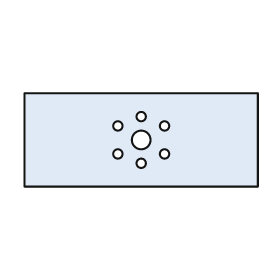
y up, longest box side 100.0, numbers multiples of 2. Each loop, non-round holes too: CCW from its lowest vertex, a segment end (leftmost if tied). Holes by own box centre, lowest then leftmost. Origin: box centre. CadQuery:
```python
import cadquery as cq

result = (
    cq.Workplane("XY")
    .moveTo(-50.0, -20.0)
    .lineTo(50.0, -20.0)
    .lineTo(50.0, 20.0)
    .lineTo(-50.0, 20.0)
    .close()
    .moveTo(0.0, -10.0)
    .circle(2.0)
    .moveTo(-10.0, -6.0)
    .circle(2.0)
    .moveTo(10.0, -6.0)
    .circle(2.0)
    .moveTo(0.0, 0.0)
    .circle(4.0)
    .moveTo(-10.0, 6.0)
    .circle(2.0)
    .moveTo(10.0, 6.0)
    .circle(2.0)
    .moveTo(0.0, 10.0)
    .circle(2.0)
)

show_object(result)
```